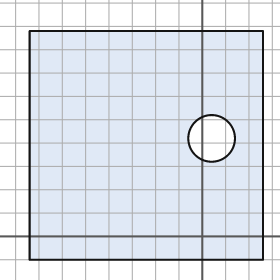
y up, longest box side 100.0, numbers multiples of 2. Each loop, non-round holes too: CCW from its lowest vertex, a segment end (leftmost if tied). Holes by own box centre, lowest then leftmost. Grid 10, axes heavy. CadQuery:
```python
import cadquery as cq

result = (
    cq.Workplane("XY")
    .moveTo(-74.0, -10.0)
    .lineTo(26.0, -10.0)
    .lineTo(26.0, 88.0)
    .lineTo(-74.0, 88.0)
    .close()
    .moveTo(4.0, 42.0)
    .circle(10.0)
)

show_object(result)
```